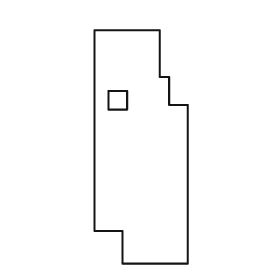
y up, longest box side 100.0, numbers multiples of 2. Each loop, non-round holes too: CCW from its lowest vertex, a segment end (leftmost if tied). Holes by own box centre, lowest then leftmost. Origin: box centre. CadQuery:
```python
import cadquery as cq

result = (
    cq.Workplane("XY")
    .moveTo(-8.0, -50.0)
    .lineTo(20.0, -50.0)
    .lineTo(20.0, 18.0)
    .lineTo(12.0, 18.0)
    .lineTo(12.0, 30.0)
    .lineTo(8.0, 30.0)
    .lineTo(8.0, 50.0)
    .lineTo(-20.0, 50.0)
    .lineTo(-20.0, -36.0)
    .lineTo(-8.0, -36.0)
    .close()
    .moveTo(-14.0, 16.0)
    .lineTo(-6.0, 16.0)
    .lineTo(-6.0, 24.0)
    .lineTo(-14.0, 24.0)
    .close()
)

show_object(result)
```